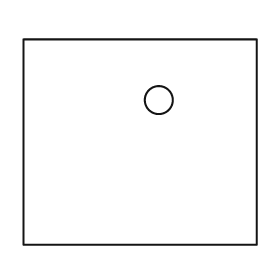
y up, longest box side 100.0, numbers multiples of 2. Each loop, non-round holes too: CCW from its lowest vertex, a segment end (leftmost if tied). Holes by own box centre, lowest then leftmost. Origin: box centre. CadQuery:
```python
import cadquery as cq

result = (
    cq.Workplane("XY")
    .moveTo(-50.0, -44.0)
    .lineTo(50.0, -44.0)
    .lineTo(50.0, 44.0)
    .lineTo(-50.0, 44.0)
    .close()
    .moveTo(8.0, 18.0)
    .circle(6.0)
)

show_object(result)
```